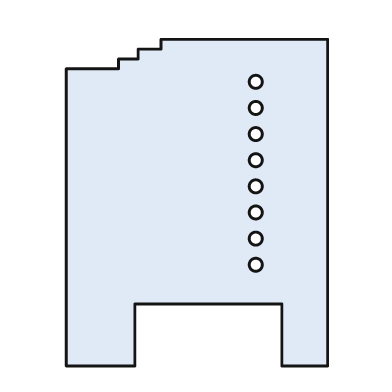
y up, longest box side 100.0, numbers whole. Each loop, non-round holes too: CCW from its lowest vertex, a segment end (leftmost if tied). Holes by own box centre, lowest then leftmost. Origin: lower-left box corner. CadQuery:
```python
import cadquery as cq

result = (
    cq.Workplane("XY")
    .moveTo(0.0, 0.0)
    .lineTo(21.0, 0.0)
    .lineTo(21.0, 19.0)
    .lineTo(66.0, 19.0)
    .lineTo(66.0, 0.0)
    .lineTo(80.0, 0.0)
    .lineTo(80.0, 100.0)
    .lineTo(29.0, 100.0)
    .lineTo(29.0, 97.0)
    .lineTo(22.0, 97.0)
    .lineTo(22.0, 94.0)
    .lineTo(16.0, 94.0)
    .lineTo(16.0, 91.0)
    .lineTo(0.0, 91.0)
    .close()
    .moveTo(58.0, 31.0)
    .circle(2.0)
    .moveTo(58.0, 39.0)
    .circle(2.0)
    .moveTo(58.0, 47.0)
    .circle(2.0)
    .moveTo(58.0, 55.0)
    .circle(2.0)
    .moveTo(58.0, 63.0)
    .circle(2.0)
    .moveTo(58.0, 71.0)
    .circle(2.0)
    .moveTo(58.0, 79.0)
    .circle(2.0)
    .moveTo(58.0, 87.0)
    .circle(2.0)
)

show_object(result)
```